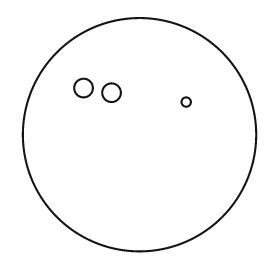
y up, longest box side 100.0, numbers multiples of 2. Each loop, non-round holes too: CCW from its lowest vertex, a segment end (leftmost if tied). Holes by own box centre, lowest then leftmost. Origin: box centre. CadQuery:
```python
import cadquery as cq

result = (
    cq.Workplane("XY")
    .moveTo(0.0, 0.0)
    .circle(50.0)
    .moveTo(20.0, 14.0)
    .circle(2.0)
    .moveTo(-12.0, 18.0)
    .circle(4.0)
    .moveTo(-24.0, 20.0)
    .circle(4.0)
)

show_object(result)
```